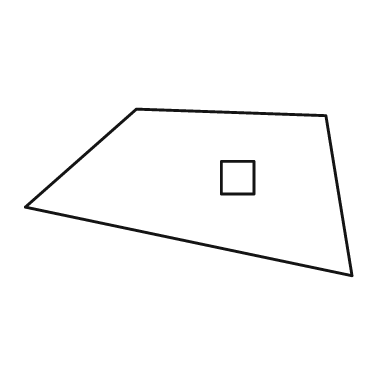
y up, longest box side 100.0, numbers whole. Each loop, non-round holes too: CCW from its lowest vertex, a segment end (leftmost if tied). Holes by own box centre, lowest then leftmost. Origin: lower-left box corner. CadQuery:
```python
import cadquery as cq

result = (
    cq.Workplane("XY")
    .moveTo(100.0, 0.0)
    .lineTo(92.0, 49.0)
    .lineTo(34.0, 51.0)
    .lineTo(0.0, 21.0)
    .close()
    .moveTo(60.0, 25.0)
    .lineTo(70.0, 25.0)
    .lineTo(70.0, 35.0)
    .lineTo(60.0, 35.0)
    .close()
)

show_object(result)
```